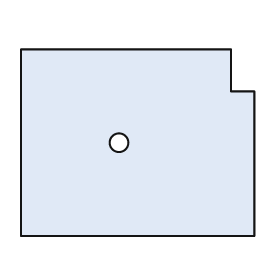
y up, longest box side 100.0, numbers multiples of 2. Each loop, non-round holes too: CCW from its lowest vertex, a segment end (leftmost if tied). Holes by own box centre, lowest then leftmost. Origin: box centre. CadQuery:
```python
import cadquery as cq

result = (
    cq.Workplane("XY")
    .moveTo(-50.0, -40.0)
    .lineTo(50.0, -40.0)
    .lineTo(50.0, 22.0)
    .lineTo(40.0, 22.0)
    .lineTo(40.0, 40.0)
    .lineTo(-50.0, 40.0)
    .close()
    .moveTo(-8.0, 0.0)
    .circle(4.0)
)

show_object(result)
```